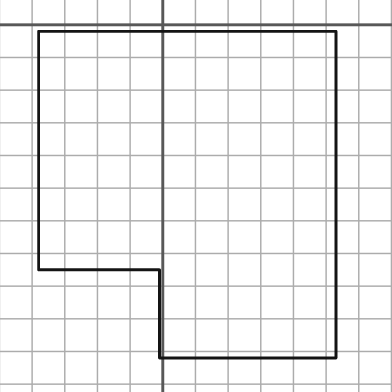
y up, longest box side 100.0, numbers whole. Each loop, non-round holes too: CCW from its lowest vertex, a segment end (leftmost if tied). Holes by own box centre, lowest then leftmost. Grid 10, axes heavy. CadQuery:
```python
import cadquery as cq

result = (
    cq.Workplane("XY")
    .moveTo(-1.0, -102.0)
    .lineTo(53.0, -102.0)
    .lineTo(53.0, -2.0)
    .lineTo(-38.0, -2.0)
    .lineTo(-38.0, -75.0)
    .lineTo(-1.0, -75.0)
    .close()
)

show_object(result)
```